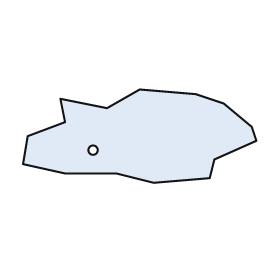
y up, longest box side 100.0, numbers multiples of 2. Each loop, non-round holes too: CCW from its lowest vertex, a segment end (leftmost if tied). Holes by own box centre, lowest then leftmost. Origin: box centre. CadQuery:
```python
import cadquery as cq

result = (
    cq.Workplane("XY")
    .moveTo(6.0, -20.0)
    .lineTo(30.0, -18.0)
    .lineTo(32.0, -10.0)
    .lineTo(50.0, -2.0)
    .lineTo(48.0, 4.0)
    .lineTo(36.0, 14.0)
    .lineTo(24.0, 18.0)
    .lineTo(0.0, 20.0)
    .lineTo(-14.0, 12.0)
    .lineTo(-34.0, 16.0)
    .lineTo(-32.0, 6.0)
    .lineTo(-48.0, 0.0)
    .lineTo(-50.0, -12.0)
    .lineTo(-32.0, -16.0)
    .lineTo(-10.0, -16.0)
    .close()
    .moveTo(-20.0, -6.0)
    .circle(2.0)
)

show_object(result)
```